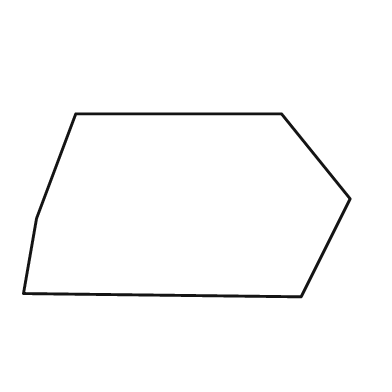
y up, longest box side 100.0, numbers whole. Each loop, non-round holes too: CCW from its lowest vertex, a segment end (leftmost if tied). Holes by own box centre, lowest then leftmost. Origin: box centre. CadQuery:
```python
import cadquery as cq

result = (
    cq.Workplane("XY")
    .moveTo(35.0, -28.0)
    .lineTo(50.0, 2.0)
    .lineTo(29.0, 28.0)
    .lineTo(-34.0, 28.0)
    .lineTo(-46.0, -4.0)
    .lineTo(-50.0, -27.0)
    .close()
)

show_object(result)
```